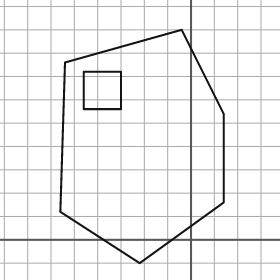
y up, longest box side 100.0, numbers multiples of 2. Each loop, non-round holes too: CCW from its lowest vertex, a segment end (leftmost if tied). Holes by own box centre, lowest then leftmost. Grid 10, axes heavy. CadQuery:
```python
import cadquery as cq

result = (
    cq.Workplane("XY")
    .moveTo(-22.0, -10.0)
    .lineTo(14.0, 16.0)
    .lineTo(14.0, 54.0)
    .lineTo(-4.0, 90.0)
    .lineTo(-54.0, 76.0)
    .lineTo(-56.0, 12.0)
    .close()
    .moveTo(-46.0, 56.0)
    .lineTo(-30.0, 56.0)
    .lineTo(-30.0, 72.0)
    .lineTo(-46.0, 72.0)
    .close()
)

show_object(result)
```